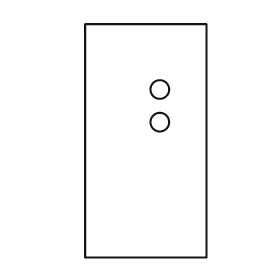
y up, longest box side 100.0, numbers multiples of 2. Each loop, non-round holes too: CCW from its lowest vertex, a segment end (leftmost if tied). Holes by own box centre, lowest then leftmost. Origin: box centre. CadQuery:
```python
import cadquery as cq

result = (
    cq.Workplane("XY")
    .moveTo(-26.0, -50.0)
    .lineTo(26.0, -50.0)
    .lineTo(26.0, 50.0)
    .lineTo(-26.0, 50.0)
    .close()
    .moveTo(6.0, 8.0)
    .circle(4.0)
    .moveTo(6.0, 22.0)
    .circle(4.0)
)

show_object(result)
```